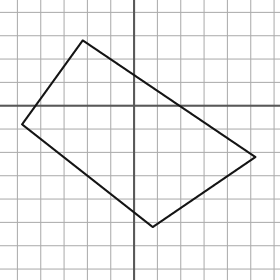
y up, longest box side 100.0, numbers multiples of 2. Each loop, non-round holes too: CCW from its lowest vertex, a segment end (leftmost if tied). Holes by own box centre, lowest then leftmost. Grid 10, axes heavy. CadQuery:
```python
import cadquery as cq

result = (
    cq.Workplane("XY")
    .moveTo(8.0, -52.0)
    .lineTo(52.0, -22.0)
    .lineTo(-22.0, 28.0)
    .lineTo(-48.0, -8.0)
    .close()
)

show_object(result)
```